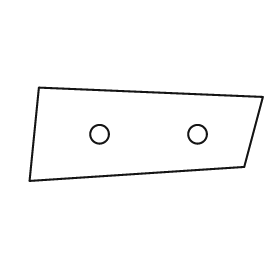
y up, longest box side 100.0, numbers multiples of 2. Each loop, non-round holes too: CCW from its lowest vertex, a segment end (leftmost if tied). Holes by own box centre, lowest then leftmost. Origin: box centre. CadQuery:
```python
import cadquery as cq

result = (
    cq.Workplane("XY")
    .moveTo(-50.0, -20.0)
    .lineTo(42.0, -14.0)
    .lineTo(50.0, 16.0)
    .lineTo(-46.0, 20.0)
    .close()
    .moveTo(-20.0, 0.0)
    .circle(4.0)
    .moveTo(22.0, 0.0)
    .circle(4.0)
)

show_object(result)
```